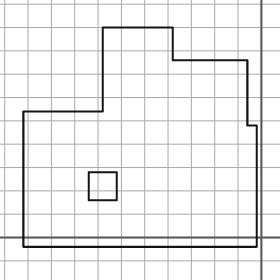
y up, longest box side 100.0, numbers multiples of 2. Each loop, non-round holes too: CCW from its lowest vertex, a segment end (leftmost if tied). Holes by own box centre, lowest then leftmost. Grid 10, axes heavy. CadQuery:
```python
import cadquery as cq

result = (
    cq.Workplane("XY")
    .moveTo(-102.0, -4.0)
    .lineTo(-2.0, -4.0)
    .lineTo(-2.0, 48.0)
    .lineTo(-6.0, 48.0)
    .lineTo(-6.0, 76.0)
    .lineTo(-38.0, 76.0)
    .lineTo(-38.0, 90.0)
    .lineTo(-68.0, 90.0)
    .lineTo(-68.0, 54.0)
    .lineTo(-102.0, 54.0)
    .close()
    .moveTo(-74.0, 16.0)
    .lineTo(-62.0, 16.0)
    .lineTo(-62.0, 28.0)
    .lineTo(-74.0, 28.0)
    .close()
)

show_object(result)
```